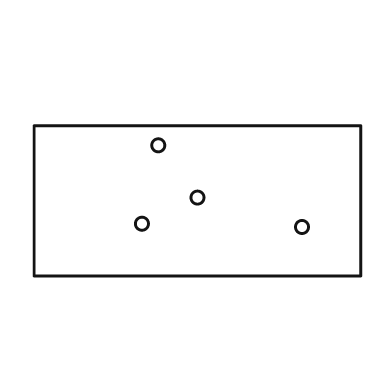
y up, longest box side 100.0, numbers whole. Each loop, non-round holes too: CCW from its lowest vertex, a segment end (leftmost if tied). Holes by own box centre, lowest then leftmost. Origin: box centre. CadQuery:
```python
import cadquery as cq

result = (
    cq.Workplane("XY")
    .moveTo(-50.0, -23.0)
    .lineTo(50.0, -23.0)
    .lineTo(50.0, 23.0)
    .lineTo(-50.0, 23.0)
    .close()
    .moveTo(32.0, -8.0)
    .circle(2.0)
    .moveTo(-17.0, -7.0)
    .circle(2.0)
    .moveTo(0.0, 1.0)
    .circle(2.0)
    .moveTo(-12.0, 17.0)
    .circle(2.0)
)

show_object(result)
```